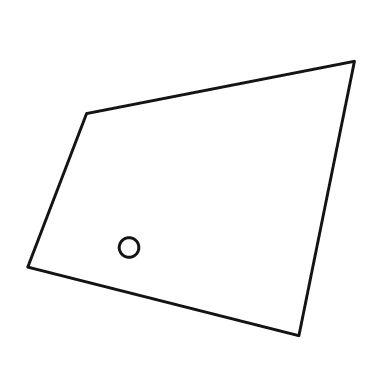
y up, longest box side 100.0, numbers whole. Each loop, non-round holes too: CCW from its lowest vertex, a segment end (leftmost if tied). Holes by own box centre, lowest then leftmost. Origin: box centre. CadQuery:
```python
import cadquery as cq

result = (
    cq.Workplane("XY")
    .moveTo(33.0, -42.0)
    .lineTo(50.0, 42.0)
    .lineTo(-32.0, 26.0)
    .lineTo(-50.0, -21.0)
    .close()
    .moveTo(-19.0, -15.0)
    .circle(3.0)
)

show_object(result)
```